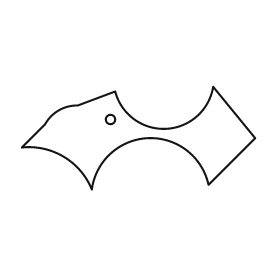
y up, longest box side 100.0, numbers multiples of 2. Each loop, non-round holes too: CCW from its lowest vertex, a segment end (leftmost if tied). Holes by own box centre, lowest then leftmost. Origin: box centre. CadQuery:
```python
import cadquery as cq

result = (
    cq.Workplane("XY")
    .moveTo(-20.0, -22.0)
    .threePointArc((4.0, 0.0), (30.0, -20.0))
    .lineTo(50.0, 0.0)
    .lineTo(32.0, 22.0)
    .threePointArc((12.0, 4.0), (-10.0, 20.0))
    .lineTo(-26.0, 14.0)
    .threePointArc((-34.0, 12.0), (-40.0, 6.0))
    .lineTo(-50.0, -4.0)
    .threePointArc((-32.0, -8.0), (-20.0, -22.0))
    .close()
    .moveTo(-12.0, 8.0)
    .circle(2.0)
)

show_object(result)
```